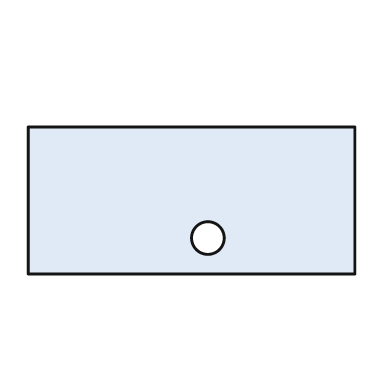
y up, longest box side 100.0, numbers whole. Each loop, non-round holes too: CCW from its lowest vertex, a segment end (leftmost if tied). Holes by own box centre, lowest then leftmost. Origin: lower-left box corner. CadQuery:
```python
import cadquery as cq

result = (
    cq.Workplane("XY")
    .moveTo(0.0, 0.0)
    .lineTo(100.0, 0.0)
    .lineTo(100.0, 45.0)
    .lineTo(0.0, 45.0)
    .close()
    .moveTo(55.0, 11.0)
    .circle(5.0)
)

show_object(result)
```